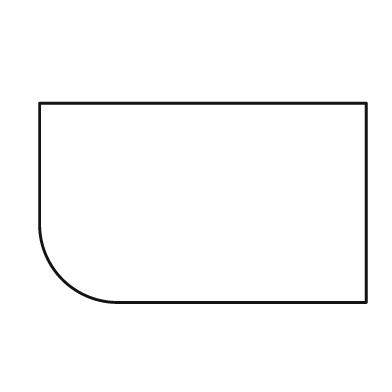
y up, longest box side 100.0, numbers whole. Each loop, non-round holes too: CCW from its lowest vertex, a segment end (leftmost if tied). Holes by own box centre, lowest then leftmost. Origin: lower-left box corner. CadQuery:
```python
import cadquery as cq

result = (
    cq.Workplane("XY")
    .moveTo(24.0, 0.0)
    .lineTo(100.0, 0.0)
    .lineTo(100.0, 61.0)
    .lineTo(0.0, 61.0)
    .lineTo(0.0, 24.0)
    .threePointArc((7.0, 7.0), (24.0, 0.0))
    .close()
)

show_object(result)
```